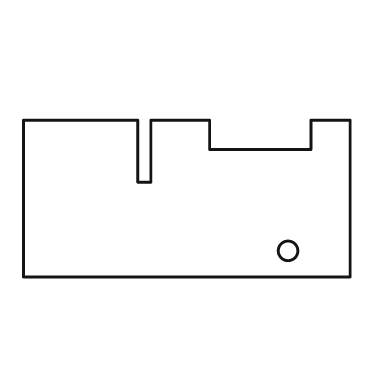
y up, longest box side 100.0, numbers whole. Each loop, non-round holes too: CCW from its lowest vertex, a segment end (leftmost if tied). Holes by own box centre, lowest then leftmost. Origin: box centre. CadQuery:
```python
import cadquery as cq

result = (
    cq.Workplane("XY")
    .moveTo(-50.0, -24.0)
    .lineTo(50.0, -24.0)
    .lineTo(50.0, 24.0)
    .lineTo(38.0, 24.0)
    .lineTo(38.0, 15.0)
    .lineTo(7.0, 15.0)
    .lineTo(7.0, 24.0)
    .lineTo(-11.0, 24.0)
    .lineTo(-11.0, 5.0)
    .lineTo(-15.0, 5.0)
    .lineTo(-15.0, 24.0)
    .lineTo(-50.0, 24.0)
    .close()
    .moveTo(31.0, -16.0)
    .circle(3.0)
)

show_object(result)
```